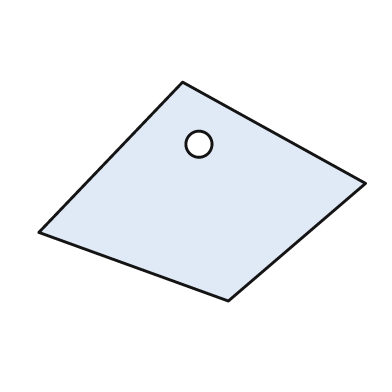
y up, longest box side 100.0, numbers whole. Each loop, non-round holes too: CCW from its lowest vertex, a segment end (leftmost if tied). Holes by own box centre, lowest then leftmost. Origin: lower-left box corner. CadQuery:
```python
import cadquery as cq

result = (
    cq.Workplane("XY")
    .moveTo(58.0, 0.0)
    .lineTo(100.0, 36.0)
    .lineTo(44.0, 67.0)
    .lineTo(0.0, 21.0)
    .close()
    .moveTo(49.0, 48.0)
    .circle(4.0)
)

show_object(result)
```